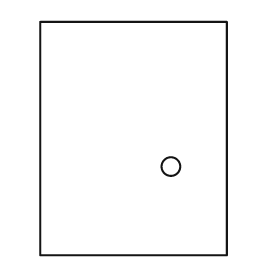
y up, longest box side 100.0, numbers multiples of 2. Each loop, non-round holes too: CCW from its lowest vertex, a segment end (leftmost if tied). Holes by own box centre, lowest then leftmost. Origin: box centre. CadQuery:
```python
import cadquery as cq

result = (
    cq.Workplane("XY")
    .moveTo(-40.0, -50.0)
    .lineTo(40.0, -50.0)
    .lineTo(40.0, 50.0)
    .lineTo(-40.0, 50.0)
    .close()
    .moveTo(16.0, -12.0)
    .circle(4.0)
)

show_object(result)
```